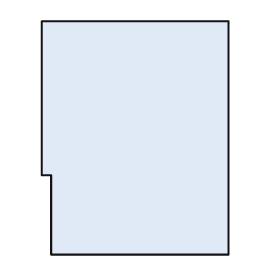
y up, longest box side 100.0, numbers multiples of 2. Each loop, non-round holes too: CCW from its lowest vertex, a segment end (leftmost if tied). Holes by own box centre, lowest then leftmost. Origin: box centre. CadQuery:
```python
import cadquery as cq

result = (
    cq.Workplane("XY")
    .moveTo(-36.0, -50.0)
    .lineTo(40.0, -50.0)
    .lineTo(40.0, 50.0)
    .lineTo(-40.0, 50.0)
    .lineTo(-40.0, -16.0)
    .lineTo(-36.0, -16.0)
    .close()
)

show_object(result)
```